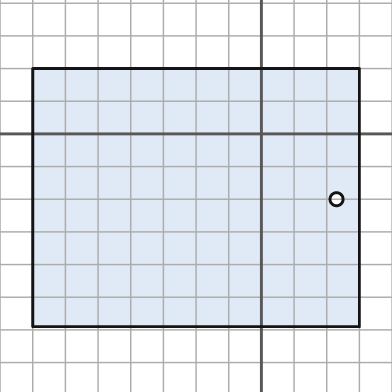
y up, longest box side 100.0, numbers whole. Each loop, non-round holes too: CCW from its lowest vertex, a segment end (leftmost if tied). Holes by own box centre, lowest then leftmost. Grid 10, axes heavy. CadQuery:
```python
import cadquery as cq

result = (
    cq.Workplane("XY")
    .moveTo(-70.0, -59.0)
    .lineTo(30.0, -59.0)
    .lineTo(30.0, 20.0)
    .lineTo(-70.0, 20.0)
    .close()
    .moveTo(23.0, -20.0)
    .circle(2.0)
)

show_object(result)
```